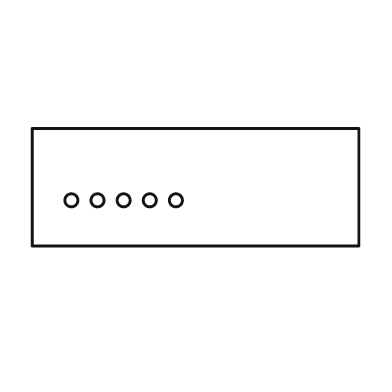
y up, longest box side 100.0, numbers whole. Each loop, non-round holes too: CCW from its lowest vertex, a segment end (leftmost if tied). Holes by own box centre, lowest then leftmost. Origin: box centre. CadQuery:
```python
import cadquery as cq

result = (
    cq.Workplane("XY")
    .moveTo(-50.0, -18.0)
    .lineTo(50.0, -18.0)
    .lineTo(50.0, 18.0)
    .lineTo(-50.0, 18.0)
    .close()
    .moveTo(-38.0, -4.0)
    .circle(2.0)
    .moveTo(-30.0, -4.0)
    .circle(2.0)
    .moveTo(-22.0, -4.0)
    .circle(2.0)
    .moveTo(-14.0, -4.0)
    .circle(2.0)
    .moveTo(-6.0, -4.0)
    .circle(2.0)
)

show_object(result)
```